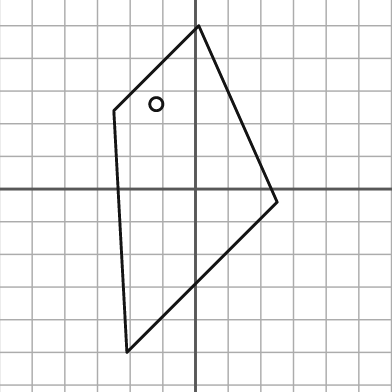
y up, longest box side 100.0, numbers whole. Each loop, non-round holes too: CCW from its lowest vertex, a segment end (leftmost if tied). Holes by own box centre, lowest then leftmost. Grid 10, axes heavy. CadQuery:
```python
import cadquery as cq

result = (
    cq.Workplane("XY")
    .moveTo(-21.0, -50.0)
    .lineTo(25.0, -4.0)
    .lineTo(1.0, 50.0)
    .lineTo(-25.0, 24.0)
    .close()
    .moveTo(-12.0, 26.0)
    .circle(2.0)
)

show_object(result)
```